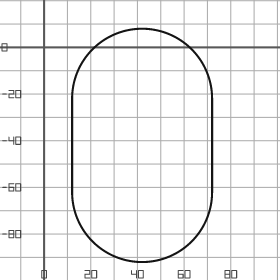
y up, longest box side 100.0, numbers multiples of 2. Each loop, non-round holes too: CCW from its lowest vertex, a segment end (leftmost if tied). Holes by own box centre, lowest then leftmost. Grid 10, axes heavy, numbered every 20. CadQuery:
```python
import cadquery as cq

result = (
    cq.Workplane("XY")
    .moveTo(12.0, -62.0)
    .threePointArc((42.0, -92.0), (72.0, -62.0))
    .lineTo(72.0, -22.0)
    .threePointArc((42.0, 8.0), (12.0, -22.0))
    .close()
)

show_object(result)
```